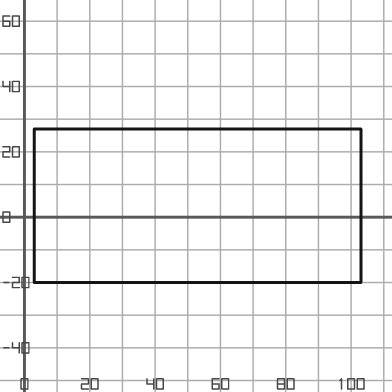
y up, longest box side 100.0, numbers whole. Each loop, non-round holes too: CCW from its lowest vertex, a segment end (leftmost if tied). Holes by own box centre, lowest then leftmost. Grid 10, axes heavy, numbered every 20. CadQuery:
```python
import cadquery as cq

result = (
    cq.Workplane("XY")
    .moveTo(3.0, -20.0)
    .lineTo(103.0, -20.0)
    .lineTo(103.0, 27.0)
    .lineTo(3.0, 27.0)
    .close()
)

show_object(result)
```